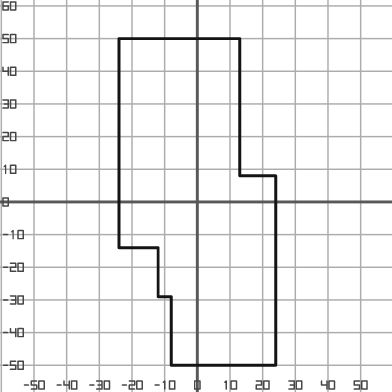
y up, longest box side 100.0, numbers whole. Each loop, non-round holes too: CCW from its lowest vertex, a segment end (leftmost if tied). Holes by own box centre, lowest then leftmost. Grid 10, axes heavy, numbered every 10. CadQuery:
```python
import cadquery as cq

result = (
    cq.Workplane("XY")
    .moveTo(-8.0, -50.0)
    .lineTo(24.0, -50.0)
    .lineTo(24.0, 8.0)
    .lineTo(13.0, 8.0)
    .lineTo(13.0, 50.0)
    .lineTo(-24.0, 50.0)
    .lineTo(-24.0, -14.0)
    .lineTo(-12.0, -14.0)
    .lineTo(-12.0, -29.0)
    .lineTo(-8.0, -29.0)
    .close()
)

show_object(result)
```